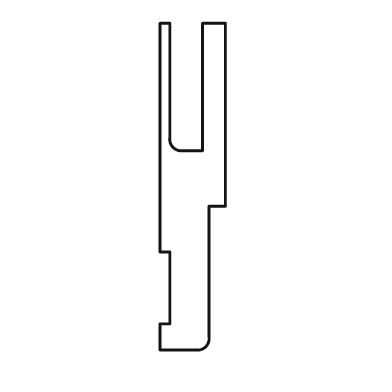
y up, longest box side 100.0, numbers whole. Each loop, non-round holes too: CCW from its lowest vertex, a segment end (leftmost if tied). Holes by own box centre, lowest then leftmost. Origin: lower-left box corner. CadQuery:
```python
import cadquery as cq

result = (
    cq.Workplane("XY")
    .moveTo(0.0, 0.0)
    .lineTo(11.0, 0.0)
    .threePointArc((14.0, 1.0), (15.0, 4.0))
    .lineTo(15.0, 44.0)
    .lineTo(20.0, 44.0)
    .lineTo(20.0, 100.0)
    .lineTo(13.0, 100.0)
    .lineTo(13.0, 61.0)
    .lineTo(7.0, 61.0)
    .threePointArc((4.0, 62.0), (3.0, 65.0))
    .lineTo(3.0, 100.0)
    .lineTo(0.0, 100.0)
    .lineTo(0.0, 30.0)
    .lineTo(3.0, 30.0)
    .lineTo(3.0, 8.0)
    .lineTo(0.0, 8.0)
    .close()
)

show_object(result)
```